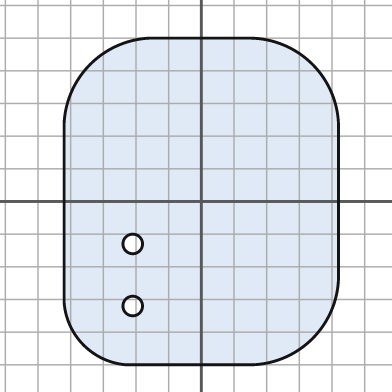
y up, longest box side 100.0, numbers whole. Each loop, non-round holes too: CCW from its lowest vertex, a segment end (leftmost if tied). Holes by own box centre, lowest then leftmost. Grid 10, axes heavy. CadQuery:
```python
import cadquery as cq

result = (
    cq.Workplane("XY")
    .moveTo(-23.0, -50.0)
    .lineTo(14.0, -50.0)
    .threePointArc((34.0, -42.0), (42.0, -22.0))
    .lineTo(42.0, 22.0)
    .threePointArc((34.0, 42.0), (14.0, 50.0))
    .lineTo(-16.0, 50.0)
    .threePointArc((-34.0, 42.0), (-42.0, 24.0))
    .lineTo(-42.0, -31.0)
    .threePointArc((-36.0, -44.0), (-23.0, -50.0))
    .close()
    .moveTo(-21.0, -32.0)
    .circle(3.0)
    .moveTo(-21.0, -13.0)
    .circle(3.0)
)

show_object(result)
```